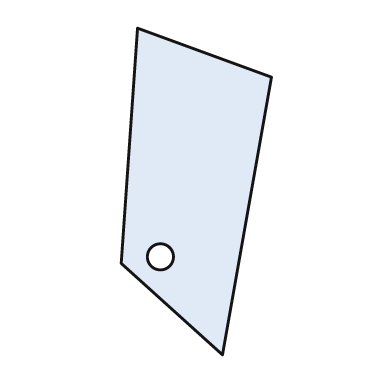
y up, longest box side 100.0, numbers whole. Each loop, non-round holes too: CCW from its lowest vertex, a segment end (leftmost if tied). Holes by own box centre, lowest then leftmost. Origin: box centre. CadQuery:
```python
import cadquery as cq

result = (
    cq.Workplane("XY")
    .moveTo(8.0, -50.0)
    .lineTo(23.0, 35.0)
    .lineTo(-18.0, 50.0)
    .lineTo(-23.0, -22.0)
    .close()
    .moveTo(-11.0, -20.0)
    .circle(4.0)
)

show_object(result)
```